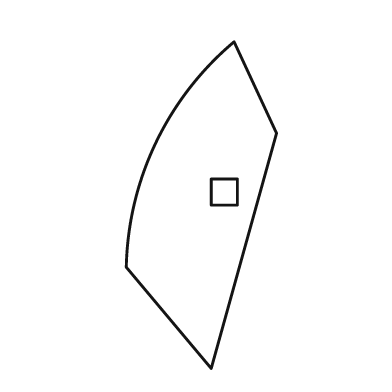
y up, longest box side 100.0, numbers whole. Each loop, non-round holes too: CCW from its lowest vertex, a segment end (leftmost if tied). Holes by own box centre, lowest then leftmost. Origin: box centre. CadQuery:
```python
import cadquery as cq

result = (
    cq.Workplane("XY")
    .moveTo(3.0, -50.0)
    .lineTo(23.0, 22.0)
    .lineTo(10.0, 50.0)
    .threePointArc((-14.0, 19.0), (-23.0, -19.0))
    .close()
    .moveTo(3.0, 0.0)
    .lineTo(11.0, 0.0)
    .lineTo(11.0, 8.0)
    .lineTo(3.0, 8.0)
    .close()
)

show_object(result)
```